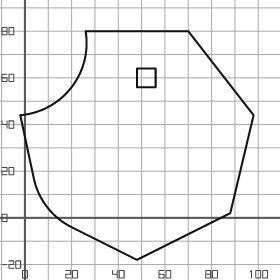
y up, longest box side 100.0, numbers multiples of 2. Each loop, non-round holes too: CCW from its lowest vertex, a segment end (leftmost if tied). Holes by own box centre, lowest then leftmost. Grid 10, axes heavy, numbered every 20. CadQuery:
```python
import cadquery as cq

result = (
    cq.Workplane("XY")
    .moveTo(48.0, -18.0)
    .lineTo(88.0, 2.0)
    .lineTo(98.0, 44.0)
    .lineTo(70.0, 80.0)
    .lineTo(26.0, 80.0)
    .threePointArc((20.0, 56.0), (-2.0, 44.0))
    .lineTo(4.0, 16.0)
    .threePointArc((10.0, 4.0), (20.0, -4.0))
    .close()
    .moveTo(48.0, 56.0)
    .lineTo(56.0, 56.0)
    .lineTo(56.0, 64.0)
    .lineTo(48.0, 64.0)
    .close()
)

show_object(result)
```